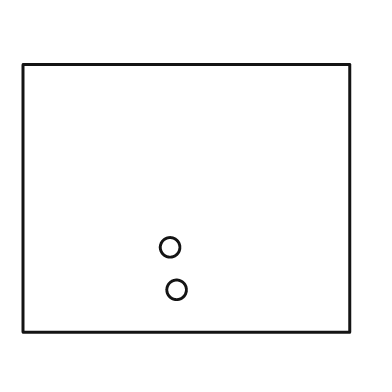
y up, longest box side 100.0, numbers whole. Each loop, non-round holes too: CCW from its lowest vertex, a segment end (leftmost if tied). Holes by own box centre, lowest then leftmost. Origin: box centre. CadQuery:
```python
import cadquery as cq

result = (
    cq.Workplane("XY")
    .moveTo(-50.0, -41.0)
    .lineTo(50.0, -41.0)
    .lineTo(50.0, 41.0)
    .lineTo(-50.0, 41.0)
    .close()
    .moveTo(-3.0, -28.0)
    .circle(3.0)
    .moveTo(-5.0, -15.0)
    .circle(3.0)
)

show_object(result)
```